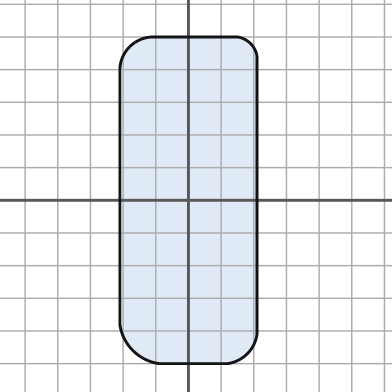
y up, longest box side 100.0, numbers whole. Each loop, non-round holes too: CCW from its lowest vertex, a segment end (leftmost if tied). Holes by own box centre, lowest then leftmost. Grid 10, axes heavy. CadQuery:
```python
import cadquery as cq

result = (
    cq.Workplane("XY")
    .moveTo(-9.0, -50.0)
    .lineTo(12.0, -50.0)
    .threePointArc((18.0, -47.0), (21.0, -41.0))
    .lineTo(21.0, 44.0)
    .threePointArc((19.0, 48.0), (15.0, 50.0))
    .lineTo(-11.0, 50.0)
    .threePointArc((-18.0, 47.0), (-21.0, 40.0))
    .lineTo(-21.0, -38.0)
    .threePointArc((-17.0, -46.0), (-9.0, -50.0))
    .close()
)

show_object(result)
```